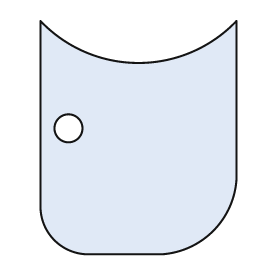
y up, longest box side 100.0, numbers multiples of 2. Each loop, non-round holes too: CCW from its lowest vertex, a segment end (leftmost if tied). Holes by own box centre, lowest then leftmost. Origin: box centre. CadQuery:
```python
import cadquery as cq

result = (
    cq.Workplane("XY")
    .moveTo(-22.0, -50.0)
    .lineTo(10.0, -50.0)
    .threePointArc((32.0, -40.0), (42.0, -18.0))
    .lineTo(42.0, 50.0)
    .threePointArc((0.0, 32.0), (-42.0, 50.0))
    .lineTo(-42.0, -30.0)
    .threePointArc((-36.0, -44.0), (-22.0, -50.0))
    .close()
    .moveTo(-30.0, 4.0)
    .circle(6.0)
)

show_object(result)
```